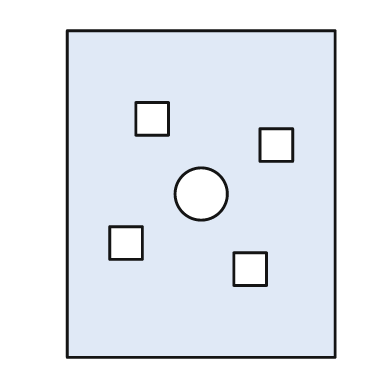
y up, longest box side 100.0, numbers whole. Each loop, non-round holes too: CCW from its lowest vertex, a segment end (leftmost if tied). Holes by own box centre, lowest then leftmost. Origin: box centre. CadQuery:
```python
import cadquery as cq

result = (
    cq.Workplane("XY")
    .moveTo(-41.0, -50.0)
    .lineTo(41.0, -50.0)
    .lineTo(41.0, 50.0)
    .lineTo(-41.0, 50.0)
    .close()
    .moveTo(10.0, -28.0)
    .lineTo(20.0, -28.0)
    .lineTo(20.0, -18.0)
    .lineTo(10.0, -18.0)
    .close()
    .moveTo(-28.0, -20.0)
    .lineTo(-18.0, -20.0)
    .lineTo(-18.0, -10.0)
    .lineTo(-28.0, -10.0)
    .close()
    .moveTo(0.0, 0.0)
    .circle(8.0)
    .moveTo(18.0, 10.0)
    .lineTo(28.0, 10.0)
    .lineTo(28.0, 20.0)
    .lineTo(18.0, 20.0)
    .close()
    .moveTo(-20.0, 18.0)
    .lineTo(-10.0, 18.0)
    .lineTo(-10.0, 28.0)
    .lineTo(-20.0, 28.0)
    .close()
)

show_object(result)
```